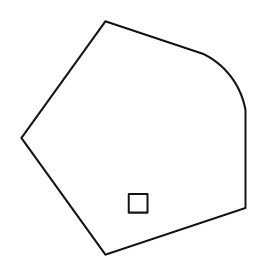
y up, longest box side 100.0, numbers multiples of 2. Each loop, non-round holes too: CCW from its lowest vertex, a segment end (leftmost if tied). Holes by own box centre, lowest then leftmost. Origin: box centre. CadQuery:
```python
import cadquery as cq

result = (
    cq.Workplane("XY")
    .moveTo(-12.0, -50.0)
    .lineTo(48.0, -30.0)
    .lineTo(48.0, 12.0)
    .threePointArc((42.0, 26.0), (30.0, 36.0))
    .lineTo(-12.0, 50.0)
    .lineTo(-48.0, 0.0)
    .close()
    .moveTo(-2.0, -32.0)
    .lineTo(6.0, -32.0)
    .lineTo(6.0, -24.0)
    .lineTo(-2.0, -24.0)
    .close()
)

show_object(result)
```